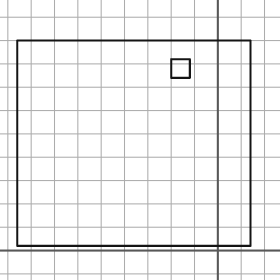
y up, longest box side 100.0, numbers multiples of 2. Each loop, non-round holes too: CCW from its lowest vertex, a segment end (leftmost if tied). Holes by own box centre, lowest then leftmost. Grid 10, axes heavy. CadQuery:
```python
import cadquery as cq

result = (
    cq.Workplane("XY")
    .moveTo(-86.0, 2.0)
    .lineTo(14.0, 2.0)
    .lineTo(14.0, 90.0)
    .lineTo(-86.0, 90.0)
    .close()
    .moveTo(-20.0, 74.0)
    .lineTo(-12.0, 74.0)
    .lineTo(-12.0, 82.0)
    .lineTo(-20.0, 82.0)
    .close()
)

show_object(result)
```